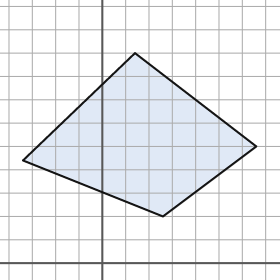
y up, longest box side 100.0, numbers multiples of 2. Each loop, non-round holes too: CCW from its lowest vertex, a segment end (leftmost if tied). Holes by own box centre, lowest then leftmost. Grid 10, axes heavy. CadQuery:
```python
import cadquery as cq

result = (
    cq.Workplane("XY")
    .moveTo(26.0, 20.0)
    .lineTo(66.0, 50.0)
    .lineTo(14.0, 90.0)
    .lineTo(-34.0, 44.0)
    .close()
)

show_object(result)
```